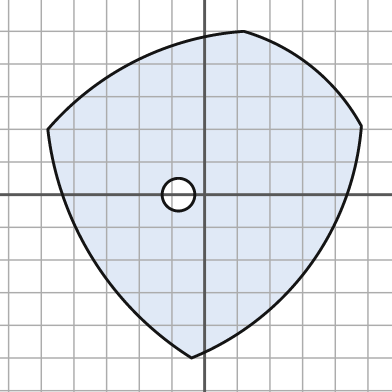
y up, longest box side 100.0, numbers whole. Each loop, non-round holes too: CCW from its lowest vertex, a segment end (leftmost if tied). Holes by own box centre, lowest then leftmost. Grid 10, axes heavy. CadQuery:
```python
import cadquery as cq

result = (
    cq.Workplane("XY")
    .moveTo(-4.0, -50.0)
    .threePointArc((32.0, -22.0), (48.0, 21.0))
    .threePointArc((33.0, 39.0), (12.0, 50.0))
    .threePointArc((-21.0, 41.0), (-48.0, 20.0))
    .threePointArc((-34.0, -20.0), (-4.0, -50.0))
    .close()
    .moveTo(-8.0, 0.0)
    .circle(5.0)
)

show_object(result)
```